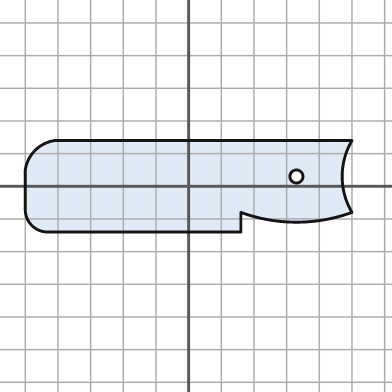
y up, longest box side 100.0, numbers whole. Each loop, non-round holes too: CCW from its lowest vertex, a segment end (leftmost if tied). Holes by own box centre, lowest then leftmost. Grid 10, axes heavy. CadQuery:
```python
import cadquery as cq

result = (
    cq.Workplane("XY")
    .moveTo(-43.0, -14.0)
    .lineTo(16.0, -14.0)
    .lineTo(16.0, -8.0)
    .threePointArc((33.0, -11.0), (50.0, -8.0))
    .threePointArc((47.0, 3.0), (50.0, 14.0))
    .lineTo(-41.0, 14.0)
    .threePointArc((-47.0, 11.0), (-50.0, 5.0))
    .lineTo(-50.0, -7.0)
    .threePointArc((-48.0, -12.0), (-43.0, -14.0))
    .close()
    .moveTo(33.0, 3.0)
    .circle(2.0)
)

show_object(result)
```